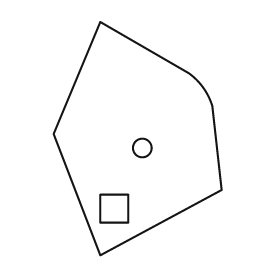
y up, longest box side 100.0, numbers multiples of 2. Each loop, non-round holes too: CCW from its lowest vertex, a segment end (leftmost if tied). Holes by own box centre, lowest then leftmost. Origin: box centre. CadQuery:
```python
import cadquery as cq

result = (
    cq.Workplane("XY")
    .moveTo(-16.0, -50.0)
    .lineTo(36.0, -22.0)
    .lineTo(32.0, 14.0)
    .threePointArc((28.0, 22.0), (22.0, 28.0))
    .lineTo(-16.0, 50.0)
    .lineTo(-36.0, 2.0)
    .close()
    .moveTo(-16.0, -36.0)
    .lineTo(-4.0, -36.0)
    .lineTo(-4.0, -24.0)
    .lineTo(-16.0, -24.0)
    .close()
    .moveTo(2.0, -4.0)
    .circle(4.0)
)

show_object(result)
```